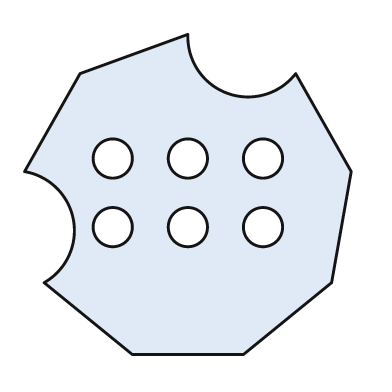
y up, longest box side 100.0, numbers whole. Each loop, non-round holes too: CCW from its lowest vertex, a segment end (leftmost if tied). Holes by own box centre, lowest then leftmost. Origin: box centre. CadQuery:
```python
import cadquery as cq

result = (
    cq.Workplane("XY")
    .moveTo(-17.0, -49.0)
    .lineTo(17.0, -49.0)
    .lineTo(44.0, -27.0)
    .lineTo(50.0, 7.0)
    .lineTo(33.0, 37.0)
    .threePointArc((12.0, 31.0), (0.0, 49.0))
    .lineTo(-33.0, 37.0)
    .lineTo(-50.0, 7.0)
    .threePointArc((-35.0, -8.0), (-44.0, -27.0))
    .close()
    .moveTo(-23.0, -10.0)
    .circle(6.0)
    .moveTo(0.0, -10.0)
    .circle(6.0)
    .moveTo(23.0, -10.0)
    .circle(6.0)
    .moveTo(-23.0, 11.0)
    .circle(6.0)
    .moveTo(0.0, 11.0)
    .circle(6.0)
    .moveTo(23.0, 11.0)
    .circle(6.0)
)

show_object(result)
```